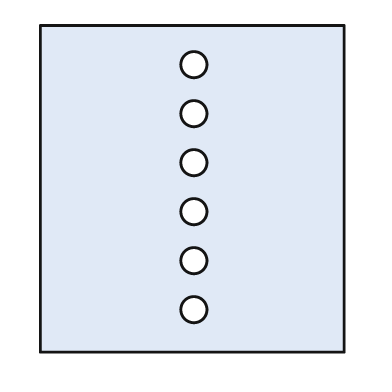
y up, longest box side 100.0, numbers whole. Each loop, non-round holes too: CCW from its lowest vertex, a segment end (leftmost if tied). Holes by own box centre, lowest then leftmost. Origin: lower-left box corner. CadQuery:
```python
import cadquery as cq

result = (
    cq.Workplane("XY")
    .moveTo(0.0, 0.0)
    .lineTo(93.0, 0.0)
    .lineTo(93.0, 100.0)
    .lineTo(0.0, 100.0)
    .close()
    .moveTo(47.0, 13.0)
    .circle(4.0)
    .moveTo(47.0, 28.0)
    .circle(4.0)
    .moveTo(47.0, 43.0)
    .circle(4.0)
    .moveTo(47.0, 58.0)
    .circle(4.0)
    .moveTo(47.0, 73.0)
    .circle(4.0)
    .moveTo(47.0, 88.0)
    .circle(4.0)
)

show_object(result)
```